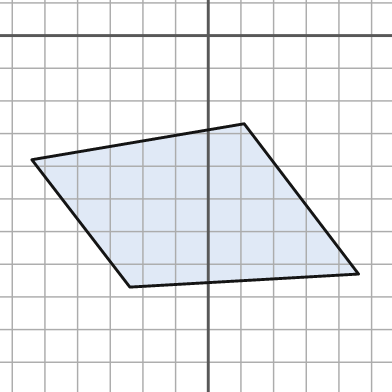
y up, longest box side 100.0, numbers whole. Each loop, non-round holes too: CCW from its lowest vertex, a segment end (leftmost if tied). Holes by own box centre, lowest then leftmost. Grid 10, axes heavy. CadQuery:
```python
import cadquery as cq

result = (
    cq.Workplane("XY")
    .moveTo(-24.0, -77.0)
    .lineTo(46.0, -73.0)
    .lineTo(11.0, -27.0)
    .lineTo(-54.0, -38.0)
    .close()
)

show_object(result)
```